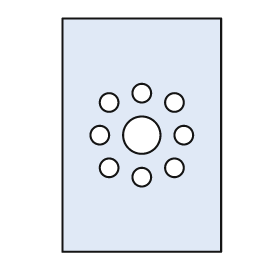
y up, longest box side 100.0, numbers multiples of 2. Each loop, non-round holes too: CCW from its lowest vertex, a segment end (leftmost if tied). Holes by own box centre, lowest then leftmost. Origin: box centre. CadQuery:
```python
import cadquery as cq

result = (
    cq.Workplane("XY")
    .moveTo(-34.0, -50.0)
    .lineTo(34.0, -50.0)
    .lineTo(34.0, 50.0)
    .lineTo(-34.0, 50.0)
    .close()
    .moveTo(0.0, -18.0)
    .circle(4.0)
    .moveTo(-14.0, -14.0)
    .circle(4.0)
    .moveTo(14.0, -14.0)
    .circle(4.0)
    .moveTo(-18.0, 0.0)
    .circle(4.0)
    .moveTo(0.0, 0.0)
    .circle(8.0)
    .moveTo(18.0, 0.0)
    .circle(4.0)
    .moveTo(-14.0, 14.0)
    .circle(4.0)
    .moveTo(14.0, 14.0)
    .circle(4.0)
    .moveTo(0.0, 18.0)
    .circle(4.0)
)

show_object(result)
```